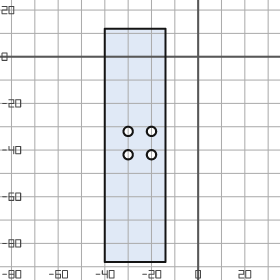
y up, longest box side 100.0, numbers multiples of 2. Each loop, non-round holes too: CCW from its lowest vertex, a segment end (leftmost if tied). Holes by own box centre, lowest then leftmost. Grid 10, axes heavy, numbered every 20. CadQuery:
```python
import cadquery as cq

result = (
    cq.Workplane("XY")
    .moveTo(-40.0, -88.0)
    .lineTo(-14.0, -88.0)
    .lineTo(-14.0, 12.0)
    .lineTo(-40.0, 12.0)
    .close()
    .moveTo(-30.0, -42.0)
    .circle(2.0)
    .moveTo(-20.0, -42.0)
    .circle(2.0)
    .moveTo(-30.0, -32.0)
    .circle(2.0)
    .moveTo(-20.0, -32.0)
    .circle(2.0)
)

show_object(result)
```